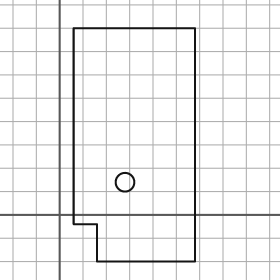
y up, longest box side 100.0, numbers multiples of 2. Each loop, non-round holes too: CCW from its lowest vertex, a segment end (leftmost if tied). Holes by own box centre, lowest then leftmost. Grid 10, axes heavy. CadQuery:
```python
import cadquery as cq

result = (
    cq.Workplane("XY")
    .moveTo(16.0, -20.0)
    .lineTo(58.0, -20.0)
    .lineTo(58.0, 80.0)
    .lineTo(6.0, 80.0)
    .lineTo(6.0, -4.0)
    .lineTo(16.0, -4.0)
    .close()
    .moveTo(28.0, 14.0)
    .circle(4.0)
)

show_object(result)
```